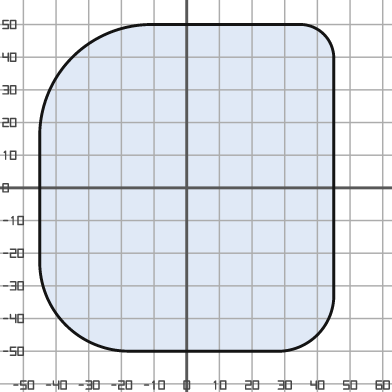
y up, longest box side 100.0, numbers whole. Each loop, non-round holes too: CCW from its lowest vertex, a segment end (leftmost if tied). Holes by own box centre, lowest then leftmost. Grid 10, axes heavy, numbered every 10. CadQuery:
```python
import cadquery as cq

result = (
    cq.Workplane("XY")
    .moveTo(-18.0, -50.0)
    .lineTo(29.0, -50.0)
    .threePointArc((40.0, -45.0), (45.0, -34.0))
    .lineTo(45.0, 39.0)
    .threePointArc((42.0, 47.0), (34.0, 50.0))
    .lineTo(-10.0, 50.0)
    .threePointArc((-35.0, 40.0), (-45.0, 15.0))
    .lineTo(-45.0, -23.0)
    .threePointArc((-37.0, -42.0), (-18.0, -50.0))
    .close()
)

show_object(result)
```